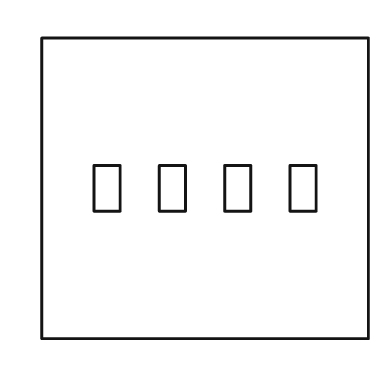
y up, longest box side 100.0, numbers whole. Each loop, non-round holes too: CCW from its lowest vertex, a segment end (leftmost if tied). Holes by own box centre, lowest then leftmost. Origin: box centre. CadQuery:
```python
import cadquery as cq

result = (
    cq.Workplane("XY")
    .moveTo(-50.0, -46.0)
    .lineTo(50.0, -46.0)
    .lineTo(50.0, 46.0)
    .lineTo(-50.0, 46.0)
    .close()
    .moveTo(-34.0, -7.0)
    .lineTo(-26.0, -7.0)
    .lineTo(-26.0, 7.0)
    .lineTo(-34.0, 7.0)
    .close()
    .moveTo(-14.0, -7.0)
    .lineTo(-6.0, -7.0)
    .lineTo(-6.0, 7.0)
    .lineTo(-14.0, 7.0)
    .close()
    .moveTo(6.0, -7.0)
    .lineTo(14.0, -7.0)
    .lineTo(14.0, 7.0)
    .lineTo(6.0, 7.0)
    .close()
    .moveTo(26.0, -7.0)
    .lineTo(34.0, -7.0)
    .lineTo(34.0, 7.0)
    .lineTo(26.0, 7.0)
    .close()
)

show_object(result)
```